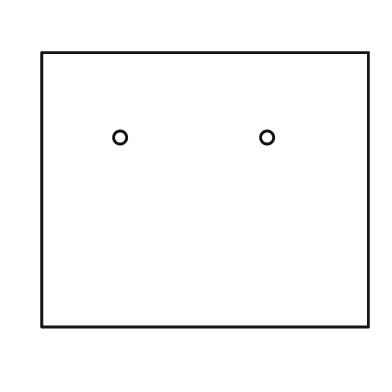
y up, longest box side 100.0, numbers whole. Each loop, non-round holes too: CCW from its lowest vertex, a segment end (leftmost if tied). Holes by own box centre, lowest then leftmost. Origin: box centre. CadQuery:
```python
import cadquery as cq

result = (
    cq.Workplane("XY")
    .moveTo(-50.0, -42.0)
    .lineTo(50.0, -42.0)
    .lineTo(50.0, 42.0)
    .lineTo(-50.0, 42.0)
    .close()
    .moveTo(-26.0, 16.0)
    .circle(2.0)
    .moveTo(19.0, 16.0)
    .circle(2.0)
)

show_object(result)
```